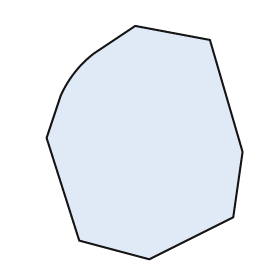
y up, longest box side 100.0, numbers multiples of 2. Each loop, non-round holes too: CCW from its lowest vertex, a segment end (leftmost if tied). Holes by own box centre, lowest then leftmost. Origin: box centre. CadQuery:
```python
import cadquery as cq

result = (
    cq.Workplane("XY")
    .moveTo(2.0, -50.0)
    .lineTo(38.0, -32.0)
    .lineTo(42.0, -4.0)
    .lineTo(28.0, 44.0)
    .lineTo(-4.0, 50.0)
    .lineTo(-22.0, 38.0)
    .threePointArc((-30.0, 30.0), (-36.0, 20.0))
    .lineTo(-42.0, 2.0)
    .lineTo(-28.0, -42.0)
    .close()
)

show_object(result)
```